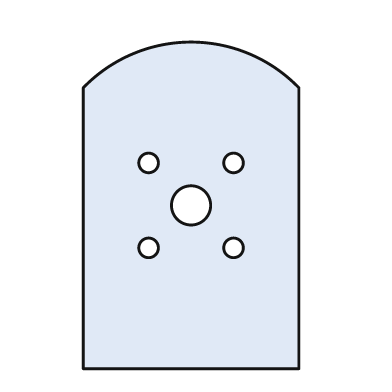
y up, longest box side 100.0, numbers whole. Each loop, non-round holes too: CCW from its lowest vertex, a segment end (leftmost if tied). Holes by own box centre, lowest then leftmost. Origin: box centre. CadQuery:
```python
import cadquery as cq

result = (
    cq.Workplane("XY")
    .moveTo(-33.0, -50.0)
    .lineTo(33.0, -50.0)
    .lineTo(33.0, 36.0)
    .threePointArc((0.0, 50.0), (-33.0, 36.0))
    .close()
    .moveTo(-13.0, -13.0)
    .circle(3.0)
    .moveTo(13.0, -13.0)
    .circle(3.0)
    .moveTo(0.0, 0.0)
    .circle(6.0)
    .moveTo(-13.0, 13.0)
    .circle(3.0)
    .moveTo(13.0, 13.0)
    .circle(3.0)
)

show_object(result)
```